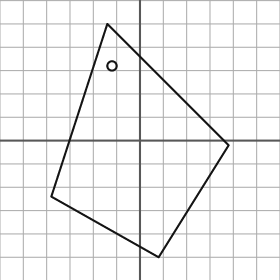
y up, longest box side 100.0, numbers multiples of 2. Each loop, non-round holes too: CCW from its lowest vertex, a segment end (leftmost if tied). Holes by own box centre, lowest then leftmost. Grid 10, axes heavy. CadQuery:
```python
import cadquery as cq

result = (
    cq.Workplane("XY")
    .moveTo(8.0, -50.0)
    .lineTo(38.0, -2.0)
    .lineTo(-14.0, 50.0)
    .lineTo(-38.0, -24.0)
    .close()
    .moveTo(-12.0, 32.0)
    .circle(2.0)
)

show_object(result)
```